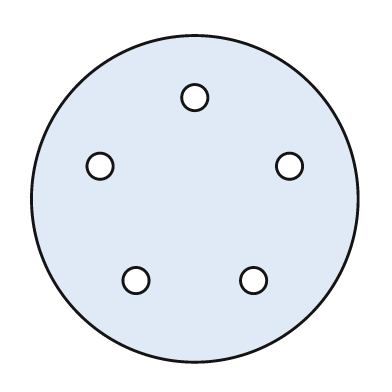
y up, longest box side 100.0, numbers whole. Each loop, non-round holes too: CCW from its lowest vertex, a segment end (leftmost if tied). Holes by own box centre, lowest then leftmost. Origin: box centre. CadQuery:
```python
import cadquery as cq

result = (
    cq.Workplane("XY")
    .moveTo(0.0, 0.0)
    .circle(50.0)
    .moveTo(-18.0, -25.0)
    .circle(4.0)
    .moveTo(18.0, -25.0)
    .circle(4.0)
    .moveTo(-29.0, 10.0)
    .circle(4.0)
    .moveTo(29.0, 10.0)
    .circle(4.0)
    .moveTo(0.0, 31.0)
    .circle(4.0)
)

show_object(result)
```